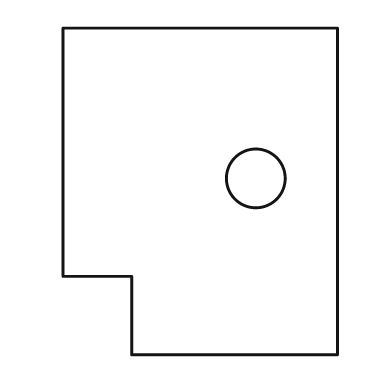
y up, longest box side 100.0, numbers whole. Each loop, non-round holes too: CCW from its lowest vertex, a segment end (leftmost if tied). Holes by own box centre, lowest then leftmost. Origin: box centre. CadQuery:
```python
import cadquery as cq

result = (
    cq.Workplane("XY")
    .moveTo(-21.0, -50.0)
    .lineTo(42.0, -50.0)
    .lineTo(42.0, 50.0)
    .lineTo(-42.0, 50.0)
    .lineTo(-42.0, -26.0)
    .lineTo(-21.0, -26.0)
    .close()
    .moveTo(17.0, 4.0)
    .circle(9.0)
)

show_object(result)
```